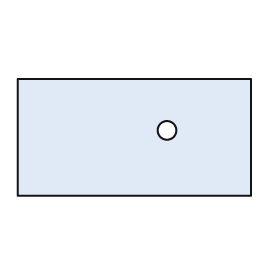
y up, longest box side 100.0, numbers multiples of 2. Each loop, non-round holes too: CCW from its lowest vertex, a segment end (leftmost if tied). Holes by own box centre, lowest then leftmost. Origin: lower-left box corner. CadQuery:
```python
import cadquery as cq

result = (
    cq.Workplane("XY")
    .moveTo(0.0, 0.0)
    .lineTo(100.0, 0.0)
    .lineTo(100.0, 50.0)
    .lineTo(0.0, 50.0)
    .close()
    .moveTo(64.0, 28.0)
    .circle(4.0)
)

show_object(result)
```